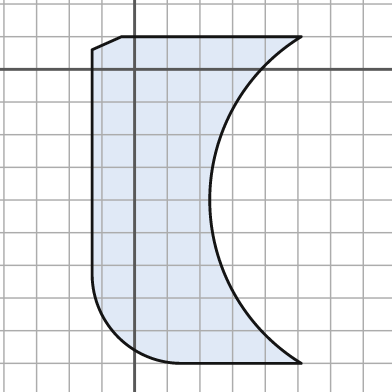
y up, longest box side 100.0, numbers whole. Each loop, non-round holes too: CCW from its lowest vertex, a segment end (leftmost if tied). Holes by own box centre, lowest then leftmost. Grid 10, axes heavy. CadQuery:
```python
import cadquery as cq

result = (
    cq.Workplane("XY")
    .moveTo(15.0, -90.0)
    .lineTo(51.0, -90.0)
    .threePointArc((23.0, -40.0), (51.0, 10.0))
    .lineTo(-4.0, 10.0)
    .lineTo(-13.0, 6.0)
    .lineTo(-13.0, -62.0)
    .threePointArc((-5.0, -82.0), (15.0, -90.0))
    .close()
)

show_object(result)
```